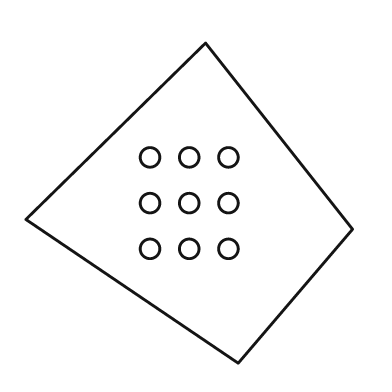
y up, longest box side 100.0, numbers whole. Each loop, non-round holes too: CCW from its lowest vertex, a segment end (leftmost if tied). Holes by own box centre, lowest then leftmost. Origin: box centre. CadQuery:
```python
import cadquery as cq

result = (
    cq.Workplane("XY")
    .moveTo(15.0, -49.0)
    .lineTo(50.0, -8.0)
    .lineTo(5.0, 49.0)
    .lineTo(-50.0, -5.0)
    .close()
    .moveTo(-12.0, -14.0)
    .circle(3.0)
    .moveTo(0.0, -14.0)
    .circle(3.0)
    .moveTo(12.0, -14.0)
    .circle(3.0)
    .moveTo(-12.0, 0.0)
    .circle(3.0)
    .moveTo(0.0, 0.0)
    .circle(3.0)
    .moveTo(12.0, 0.0)
    .circle(3.0)
    .moveTo(-12.0, 14.0)
    .circle(3.0)
    .moveTo(0.0, 14.0)
    .circle(3.0)
    .moveTo(12.0, 14.0)
    .circle(3.0)
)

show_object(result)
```